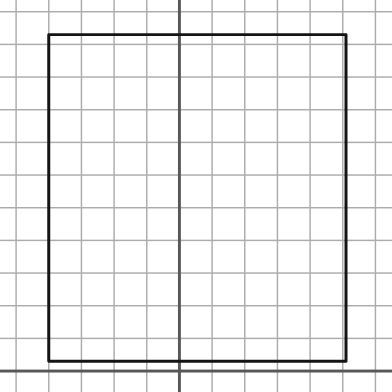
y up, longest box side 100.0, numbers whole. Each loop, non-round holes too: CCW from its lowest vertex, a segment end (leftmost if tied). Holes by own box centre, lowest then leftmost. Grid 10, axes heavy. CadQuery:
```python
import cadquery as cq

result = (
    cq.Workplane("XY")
    .moveTo(-40.0, 3.0)
    .lineTo(51.0, 3.0)
    .lineTo(51.0, 103.0)
    .lineTo(-40.0, 103.0)
    .close()
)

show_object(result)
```